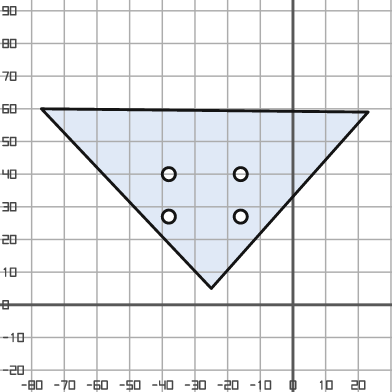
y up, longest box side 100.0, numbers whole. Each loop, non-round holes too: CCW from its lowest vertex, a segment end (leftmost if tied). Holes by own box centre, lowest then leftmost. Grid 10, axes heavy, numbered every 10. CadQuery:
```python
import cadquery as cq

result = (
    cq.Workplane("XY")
    .moveTo(-25.0, 5.0)
    .lineTo(23.0, 59.0)
    .lineTo(-77.0, 60.0)
    .close()
    .moveTo(-38.0, 27.0)
    .circle(2.0)
    .moveTo(-16.0, 27.0)
    .circle(2.0)
    .moveTo(-38.0, 40.0)
    .circle(2.0)
    .moveTo(-16.0, 40.0)
    .circle(2.0)
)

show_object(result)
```